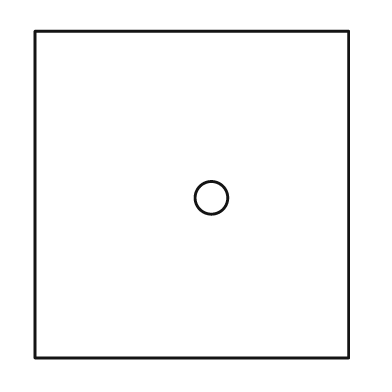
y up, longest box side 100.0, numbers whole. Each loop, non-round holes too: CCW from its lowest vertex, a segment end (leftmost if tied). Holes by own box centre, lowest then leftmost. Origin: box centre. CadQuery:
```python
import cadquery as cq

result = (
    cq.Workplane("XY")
    .moveTo(-48.0, -50.0)
    .lineTo(48.0, -50.0)
    .lineTo(48.0, 50.0)
    .lineTo(-48.0, 50.0)
    .close()
    .moveTo(6.0, -1.0)
    .circle(5.0)
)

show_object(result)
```